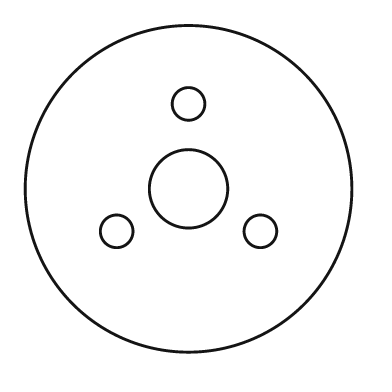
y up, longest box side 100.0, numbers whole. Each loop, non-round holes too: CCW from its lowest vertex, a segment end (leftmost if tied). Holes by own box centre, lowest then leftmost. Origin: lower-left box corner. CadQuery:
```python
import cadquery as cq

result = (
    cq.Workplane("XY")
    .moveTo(50.0, 50.0)
    .circle(50.0)
    .moveTo(28.0, 37.0)
    .circle(5.0)
    .moveTo(72.0, 37.0)
    .circle(5.0)
    .moveTo(50.0, 50.0)
    .circle(12.0)
    .moveTo(50.0, 76.0)
    .circle(5.0)
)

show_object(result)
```